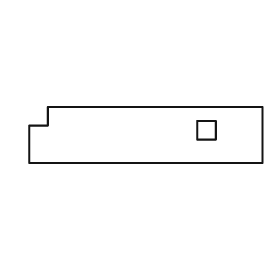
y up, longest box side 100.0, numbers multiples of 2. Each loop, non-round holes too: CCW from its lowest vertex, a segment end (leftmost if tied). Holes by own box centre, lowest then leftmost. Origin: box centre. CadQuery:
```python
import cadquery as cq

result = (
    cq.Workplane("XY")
    .moveTo(-50.0, -12.0)
    .lineTo(50.0, -12.0)
    .lineTo(50.0, 12.0)
    .lineTo(-42.0, 12.0)
    .lineTo(-42.0, 4.0)
    .lineTo(-50.0, 4.0)
    .close()
    .moveTo(22.0, -2.0)
    .lineTo(30.0, -2.0)
    .lineTo(30.0, 6.0)
    .lineTo(22.0, 6.0)
    .close()
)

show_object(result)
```